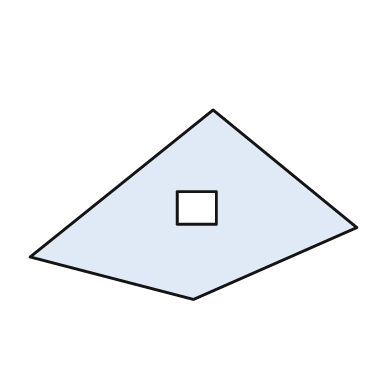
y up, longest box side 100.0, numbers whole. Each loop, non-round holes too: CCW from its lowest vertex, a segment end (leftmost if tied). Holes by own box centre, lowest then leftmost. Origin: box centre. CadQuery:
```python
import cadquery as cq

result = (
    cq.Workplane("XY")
    .moveTo(0.0, -29.0)
    .lineTo(50.0, -7.0)
    .lineTo(6.0, 29.0)
    .lineTo(-50.0, -16.0)
    .close()
    .moveTo(-5.0, -6.0)
    .lineTo(7.0, -6.0)
    .lineTo(7.0, 4.0)
    .lineTo(-5.0, 4.0)
    .close()
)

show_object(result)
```